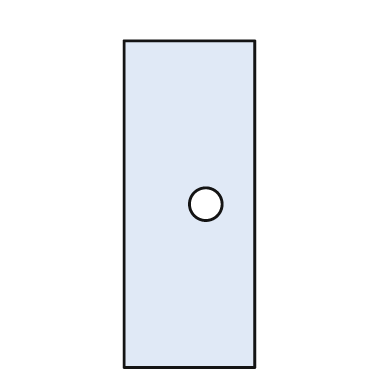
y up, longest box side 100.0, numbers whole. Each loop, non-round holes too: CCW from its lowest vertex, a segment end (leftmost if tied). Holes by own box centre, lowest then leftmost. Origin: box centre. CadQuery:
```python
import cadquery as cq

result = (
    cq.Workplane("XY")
    .moveTo(-20.0, -50.0)
    .lineTo(20.0, -50.0)
    .lineTo(20.0, 50.0)
    .lineTo(-20.0, 50.0)
    .close()
    .moveTo(5.0, 0.0)
    .circle(5.0)
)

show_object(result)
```